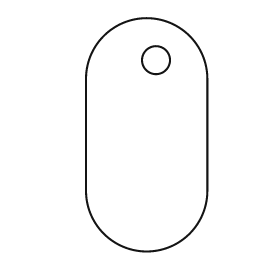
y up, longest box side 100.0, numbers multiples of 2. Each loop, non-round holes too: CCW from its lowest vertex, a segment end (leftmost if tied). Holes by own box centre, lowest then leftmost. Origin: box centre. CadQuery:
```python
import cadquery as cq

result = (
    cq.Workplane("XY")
    .moveTo(-26.0, -24.0)
    .threePointArc((0.0, -50.0), (26.0, -24.0))
    .lineTo(26.0, 24.0)
    .threePointArc((0.0, 50.0), (-26.0, 24.0))
    .close()
    .moveTo(4.0, 32.0)
    .circle(6.0)
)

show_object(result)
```